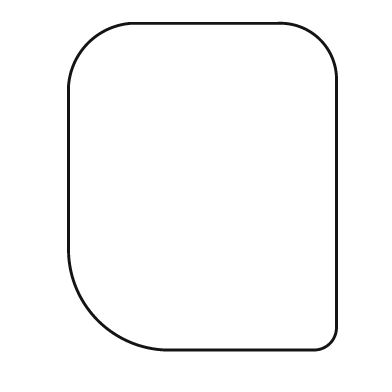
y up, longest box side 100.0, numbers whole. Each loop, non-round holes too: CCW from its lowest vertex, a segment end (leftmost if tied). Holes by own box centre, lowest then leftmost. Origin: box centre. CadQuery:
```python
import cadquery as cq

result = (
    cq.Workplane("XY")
    .moveTo(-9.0, -50.0)
    .lineTo(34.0, -50.0)
    .threePointArc((39.0, -48.0), (41.0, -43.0))
    .lineTo(41.0, 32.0)
    .threePointArc((36.0, 45.0), (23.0, 50.0))
    .lineTo(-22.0, 50.0)
    .threePointArc((-35.0, 44.0), (-41.0, 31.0))
    .lineTo(-41.0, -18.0)
    .threePointArc((-32.0, -41.0), (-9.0, -50.0))
    .close()
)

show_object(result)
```